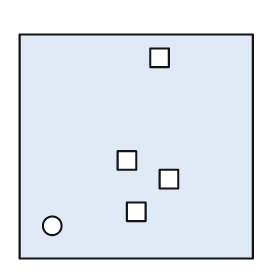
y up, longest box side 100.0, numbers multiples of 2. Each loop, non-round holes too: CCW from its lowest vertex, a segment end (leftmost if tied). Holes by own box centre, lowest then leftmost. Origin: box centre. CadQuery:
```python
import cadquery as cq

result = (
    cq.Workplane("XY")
    .moveTo(-50.0, -48.0)
    .lineTo(50.0, -48.0)
    .lineTo(50.0, 48.0)
    .lineTo(-50.0, 48.0)
    .close()
    .moveTo(-36.0, -34.0)
    .circle(4.0)
    .moveTo(-4.0, -32.0)
    .lineTo(4.0, -32.0)
    .lineTo(4.0, -24.0)
    .lineTo(-4.0, -24.0)
    .close()
    .moveTo(10.0, -18.0)
    .lineTo(18.0, -18.0)
    .lineTo(18.0, -10.0)
    .lineTo(10.0, -10.0)
    .close()
    .moveTo(-8.0, -10.0)
    .lineTo(0.0, -10.0)
    .lineTo(0.0, -2.0)
    .lineTo(-8.0, -2.0)
    .close()
    .moveTo(6.0, 34.0)
    .lineTo(14.0, 34.0)
    .lineTo(14.0, 42.0)
    .lineTo(6.0, 42.0)
    .close()
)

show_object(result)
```